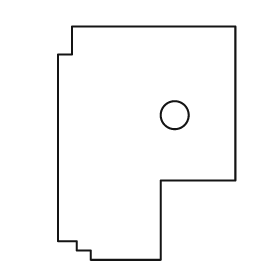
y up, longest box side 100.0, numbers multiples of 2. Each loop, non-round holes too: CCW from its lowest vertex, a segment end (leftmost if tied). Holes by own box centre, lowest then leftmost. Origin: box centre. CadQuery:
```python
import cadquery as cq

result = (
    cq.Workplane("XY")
    .moveTo(-24.0, -50.0)
    .lineTo(6.0, -50.0)
    .lineTo(6.0, -16.0)
    .lineTo(38.0, -16.0)
    .lineTo(38.0, 50.0)
    .lineTo(-32.0, 50.0)
    .lineTo(-32.0, 38.0)
    .lineTo(-38.0, 38.0)
    .lineTo(-38.0, -42.0)
    .lineTo(-30.0, -42.0)
    .lineTo(-30.0, -46.0)
    .lineTo(-24.0, -46.0)
    .close()
    .moveTo(12.0, 12.0)
    .circle(6.0)
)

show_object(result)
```